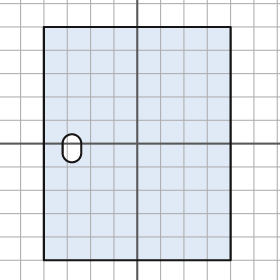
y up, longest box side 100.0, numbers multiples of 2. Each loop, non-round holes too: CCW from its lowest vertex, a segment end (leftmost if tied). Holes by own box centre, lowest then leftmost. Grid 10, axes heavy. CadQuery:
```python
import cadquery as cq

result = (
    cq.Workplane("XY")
    .moveTo(-40.0, -50.0)
    .lineTo(40.0, -50.0)
    .lineTo(40.0, 50.0)
    .lineTo(-40.0, 50.0)
    .close()
    .moveTo(-32.0, -4.0)
    .threePointArc((-28.0, -8.0), (-24.0, -4.0))
    .lineTo(-24.0, 0.0)
    .threePointArc((-28.0, 4.0), (-32.0, 0.0))
    .close()
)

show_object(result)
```